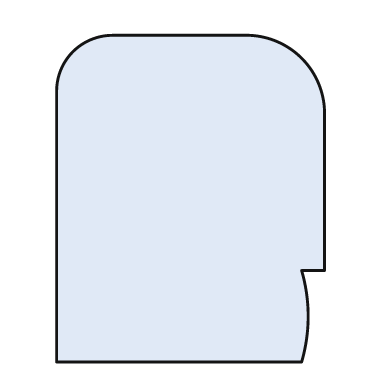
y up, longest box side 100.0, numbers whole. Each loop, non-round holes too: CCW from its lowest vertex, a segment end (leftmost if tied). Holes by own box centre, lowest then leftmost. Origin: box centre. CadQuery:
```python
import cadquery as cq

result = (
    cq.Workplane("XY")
    .moveTo(-41.0, -50.0)
    .lineTo(34.0, -50.0)
    .threePointArc((36.0, -36.0), (34.0, -22.0))
    .lineTo(41.0, -22.0)
    .lineTo(41.0, 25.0)
    .threePointArc((34.0, 43.0), (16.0, 50.0))
    .lineTo(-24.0, 50.0)
    .threePointArc((-36.0, 45.0), (-41.0, 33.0))
    .close()
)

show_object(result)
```